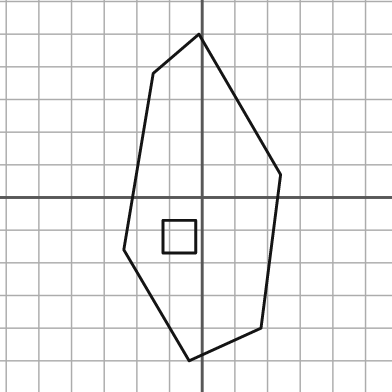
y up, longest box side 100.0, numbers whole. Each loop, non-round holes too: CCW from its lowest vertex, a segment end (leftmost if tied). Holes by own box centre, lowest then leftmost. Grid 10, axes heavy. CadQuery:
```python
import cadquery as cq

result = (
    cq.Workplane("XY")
    .moveTo(-4.0, -50.0)
    .lineTo(18.0, -40.0)
    .lineTo(24.0, 7.0)
    .lineTo(-1.0, 50.0)
    .lineTo(-15.0, 38.0)
    .lineTo(-24.0, -16.0)
    .close()
    .moveTo(-12.0, -17.0)
    .lineTo(-2.0, -17.0)
    .lineTo(-2.0, -7.0)
    .lineTo(-12.0, -7.0)
    .close()
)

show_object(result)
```